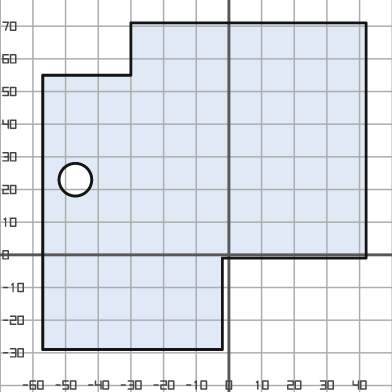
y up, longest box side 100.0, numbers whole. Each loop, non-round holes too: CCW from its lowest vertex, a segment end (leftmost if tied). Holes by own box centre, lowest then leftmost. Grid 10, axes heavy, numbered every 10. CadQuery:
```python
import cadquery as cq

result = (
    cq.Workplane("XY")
    .moveTo(-57.0, -29.0)
    .lineTo(-2.0, -29.0)
    .lineTo(-2.0, -1.0)
    .lineTo(42.0, -1.0)
    .lineTo(42.0, 71.0)
    .lineTo(-30.0, 71.0)
    .lineTo(-30.0, 55.0)
    .lineTo(-57.0, 55.0)
    .close()
    .moveTo(-47.0, 23.0)
    .circle(5.0)
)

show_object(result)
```